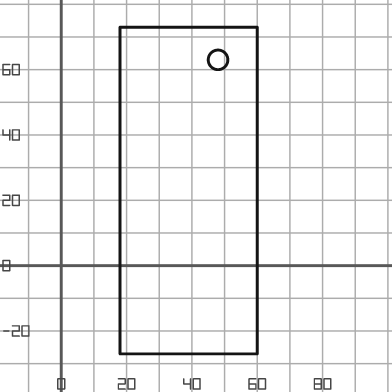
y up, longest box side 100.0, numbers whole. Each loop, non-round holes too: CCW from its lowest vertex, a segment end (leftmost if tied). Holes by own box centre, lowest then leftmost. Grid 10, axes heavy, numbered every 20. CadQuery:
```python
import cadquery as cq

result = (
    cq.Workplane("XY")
    .moveTo(18.0, -27.0)
    .lineTo(60.0, -27.0)
    .lineTo(60.0, 73.0)
    .lineTo(18.0, 73.0)
    .close()
    .moveTo(48.0, 63.0)
    .circle(3.0)
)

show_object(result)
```